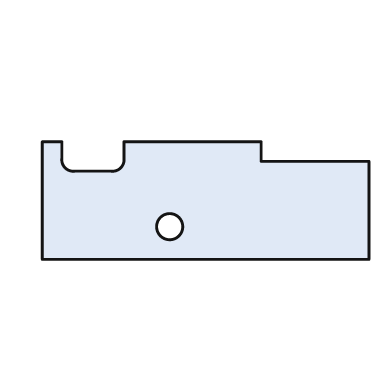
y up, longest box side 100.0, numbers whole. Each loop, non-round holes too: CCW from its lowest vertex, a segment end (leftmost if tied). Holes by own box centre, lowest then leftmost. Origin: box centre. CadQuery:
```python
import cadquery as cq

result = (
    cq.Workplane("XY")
    .moveTo(-50.0, -18.0)
    .lineTo(50.0, -18.0)
    .lineTo(50.0, 12.0)
    .lineTo(17.0, 12.0)
    .lineTo(17.0, 18.0)
    .lineTo(-25.0, 18.0)
    .lineTo(-25.0, 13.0)
    .threePointArc((-26.0, 10.0), (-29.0, 9.0))
    .lineTo(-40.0, 9.0)
    .threePointArc((-43.0, 10.0), (-44.0, 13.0))
    .lineTo(-44.0, 18.0)
    .lineTo(-50.0, 18.0)
    .close()
    .moveTo(-11.0, -8.0)
    .circle(4.0)
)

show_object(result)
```